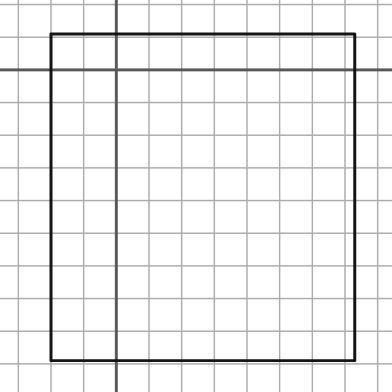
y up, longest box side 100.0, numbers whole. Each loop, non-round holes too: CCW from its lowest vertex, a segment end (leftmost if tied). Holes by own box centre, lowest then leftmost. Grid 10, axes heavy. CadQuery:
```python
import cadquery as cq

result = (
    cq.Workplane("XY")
    .moveTo(-20.0, -89.0)
    .lineTo(73.0, -89.0)
    .lineTo(73.0, 11.0)
    .lineTo(-20.0, 11.0)
    .close()
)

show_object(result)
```